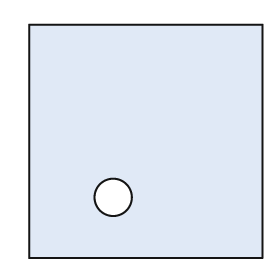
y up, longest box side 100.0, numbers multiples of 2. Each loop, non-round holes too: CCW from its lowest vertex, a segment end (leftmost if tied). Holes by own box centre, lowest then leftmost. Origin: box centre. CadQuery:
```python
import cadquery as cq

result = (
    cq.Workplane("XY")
    .moveTo(-50.0, -50.0)
    .lineTo(50.0, -50.0)
    .lineTo(50.0, 50.0)
    .lineTo(-50.0, 50.0)
    .close()
    .moveTo(-14.0, -24.0)
    .circle(8.0)
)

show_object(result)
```